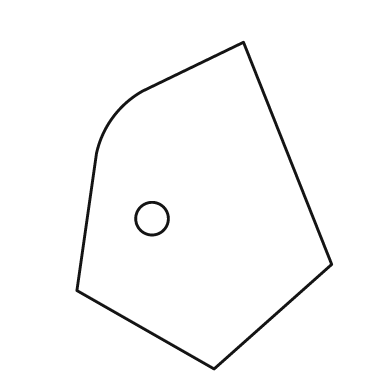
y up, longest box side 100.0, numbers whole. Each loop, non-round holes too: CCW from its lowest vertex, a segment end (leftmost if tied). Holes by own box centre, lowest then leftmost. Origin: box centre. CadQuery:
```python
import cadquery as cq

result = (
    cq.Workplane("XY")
    .moveTo(3.0, -50.0)
    .lineTo(39.0, -18.0)
    .lineTo(12.0, 50.0)
    .lineTo(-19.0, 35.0)
    .threePointArc((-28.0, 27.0), (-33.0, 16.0))
    .lineTo(-39.0, -26.0)
    .close()
    .moveTo(-16.0, -4.0)
    .circle(5.0)
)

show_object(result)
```